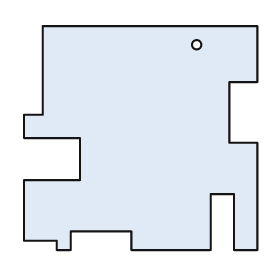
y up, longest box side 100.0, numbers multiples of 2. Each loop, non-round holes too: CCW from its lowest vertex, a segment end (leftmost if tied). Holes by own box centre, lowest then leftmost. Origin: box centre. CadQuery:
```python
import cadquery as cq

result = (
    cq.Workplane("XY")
    .moveTo(-36.0, -48.0)
    .lineTo(-30.0, -48.0)
    .lineTo(-30.0, -40.0)
    .lineTo(-4.0, -40.0)
    .lineTo(-4.0, -48.0)
    .lineTo(30.0, -48.0)
    .lineTo(30.0, -24.0)
    .lineTo(40.0, -24.0)
    .lineTo(40.0, -48.0)
    .lineTo(50.0, -48.0)
    .lineTo(50.0, -2.0)
    .lineTo(38.0, -2.0)
    .lineTo(38.0, 24.0)
    .lineTo(50.0, 24.0)
    .lineTo(50.0, 48.0)
    .lineTo(-42.0, 48.0)
    .lineTo(-42.0, 10.0)
    .lineTo(-50.0, 10.0)
    .lineTo(-50.0, 0.0)
    .lineTo(-26.0, 0.0)
    .lineTo(-26.0, -18.0)
    .lineTo(-50.0, -18.0)
    .lineTo(-50.0, -44.0)
    .lineTo(-36.0, -44.0)
    .close()
    .moveTo(24.0, 40.0)
    .circle(2.0)
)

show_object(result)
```